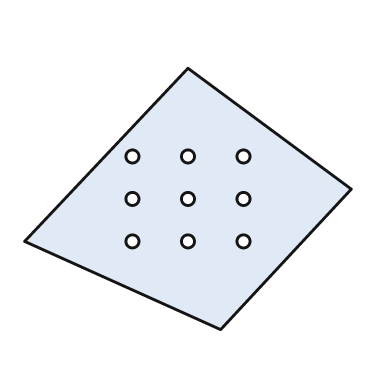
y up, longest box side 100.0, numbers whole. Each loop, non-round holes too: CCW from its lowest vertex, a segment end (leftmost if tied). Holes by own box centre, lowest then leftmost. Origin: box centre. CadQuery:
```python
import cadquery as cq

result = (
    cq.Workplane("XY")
    .moveTo(10.0, -40.0)
    .lineTo(50.0, 3.0)
    .lineTo(0.0, 40.0)
    .lineTo(-50.0, -13.0)
    .close()
    .moveTo(-17.0, -13.0)
    .circle(2.0)
    .moveTo(0.0, -13.0)
    .circle(2.0)
    .moveTo(17.0, -13.0)
    .circle(2.0)
    .moveTo(-17.0, 0.0)
    .circle(2.0)
    .moveTo(0.0, 0.0)
    .circle(2.0)
    .moveTo(17.0, 0.0)
    .circle(2.0)
    .moveTo(-17.0, 13.0)
    .circle(2.0)
    .moveTo(0.0, 13.0)
    .circle(2.0)
    .moveTo(17.0, 13.0)
    .circle(2.0)
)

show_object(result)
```